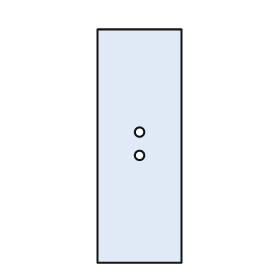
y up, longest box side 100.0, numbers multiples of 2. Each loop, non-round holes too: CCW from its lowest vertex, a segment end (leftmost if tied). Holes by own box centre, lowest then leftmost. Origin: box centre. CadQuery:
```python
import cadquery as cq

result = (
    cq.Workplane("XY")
    .moveTo(-18.0, -50.0)
    .lineTo(18.0, -50.0)
    .lineTo(18.0, 50.0)
    .lineTo(-18.0, 50.0)
    .close()
    .moveTo(0.0, -4.0)
    .circle(2.0)
    .moveTo(0.0, 6.0)
    .circle(2.0)
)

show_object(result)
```